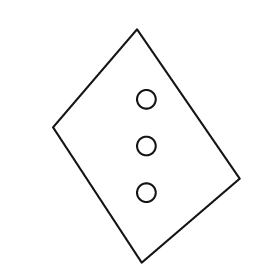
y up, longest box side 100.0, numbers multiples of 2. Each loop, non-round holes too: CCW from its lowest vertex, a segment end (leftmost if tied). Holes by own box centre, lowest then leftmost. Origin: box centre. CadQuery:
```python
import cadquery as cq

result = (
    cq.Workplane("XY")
    .moveTo(-2.0, -50.0)
    .lineTo(40.0, -14.0)
    .lineTo(-4.0, 50.0)
    .lineTo(-40.0, 8.0)
    .close()
    .moveTo(0.0, -20.0)
    .circle(4.0)
    .moveTo(0.0, 0.0)
    .circle(4.0)
    .moveTo(0.0, 20.0)
    .circle(4.0)
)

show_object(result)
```